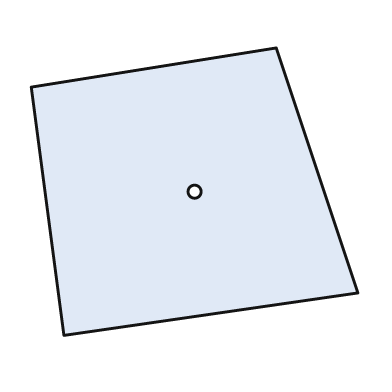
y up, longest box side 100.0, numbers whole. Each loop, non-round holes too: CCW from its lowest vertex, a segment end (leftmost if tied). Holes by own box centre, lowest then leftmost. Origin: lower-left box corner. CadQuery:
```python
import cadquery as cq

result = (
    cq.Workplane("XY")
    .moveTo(10.0, 0.0)
    .lineTo(100.0, 13.0)
    .lineTo(75.0, 88.0)
    .lineTo(0.0, 76.0)
    .close()
    .moveTo(50.0, 44.0)
    .circle(2.0)
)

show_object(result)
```